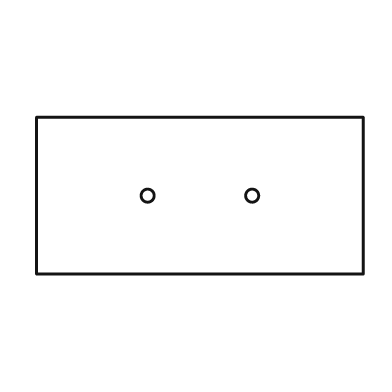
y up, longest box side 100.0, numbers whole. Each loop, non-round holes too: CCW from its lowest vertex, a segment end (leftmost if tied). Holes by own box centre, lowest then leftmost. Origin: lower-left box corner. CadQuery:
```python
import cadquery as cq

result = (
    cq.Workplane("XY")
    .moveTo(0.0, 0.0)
    .lineTo(100.0, 0.0)
    .lineTo(100.0, 48.0)
    .lineTo(0.0, 48.0)
    .close()
    .moveTo(34.0, 24.0)
    .circle(2.0)
    .moveTo(66.0, 24.0)
    .circle(2.0)
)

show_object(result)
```